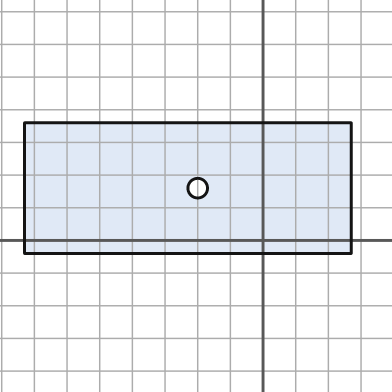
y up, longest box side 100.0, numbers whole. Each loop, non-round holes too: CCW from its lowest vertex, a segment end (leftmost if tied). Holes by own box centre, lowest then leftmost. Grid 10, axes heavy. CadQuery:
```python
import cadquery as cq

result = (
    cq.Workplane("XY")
    .moveTo(-73.0, -4.0)
    .lineTo(27.0, -4.0)
    .lineTo(27.0, 36.0)
    .lineTo(-73.0, 36.0)
    .close()
    .moveTo(-20.0, 16.0)
    .circle(3.0)
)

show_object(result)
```